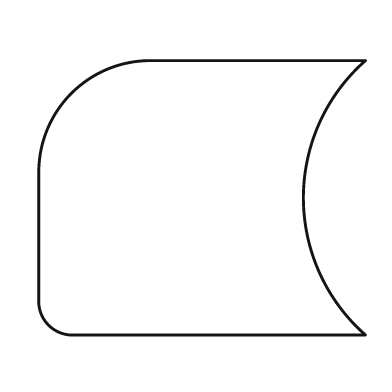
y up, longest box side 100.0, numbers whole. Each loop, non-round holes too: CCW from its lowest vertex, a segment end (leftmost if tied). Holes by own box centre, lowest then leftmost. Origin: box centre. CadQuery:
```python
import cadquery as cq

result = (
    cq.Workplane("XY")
    .moveTo(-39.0, -42.0)
    .lineTo(50.0, -42.0)
    .threePointArc((31.0, 0.0), (50.0, 42.0))
    .lineTo(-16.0, 42.0)
    .threePointArc((-40.0, 32.0), (-50.0, 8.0))
    .lineTo(-50.0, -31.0)
    .threePointArc((-47.0, -39.0), (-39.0, -42.0))
    .close()
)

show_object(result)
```